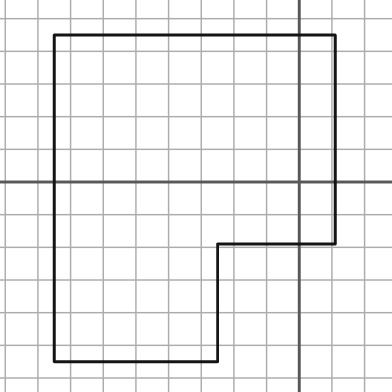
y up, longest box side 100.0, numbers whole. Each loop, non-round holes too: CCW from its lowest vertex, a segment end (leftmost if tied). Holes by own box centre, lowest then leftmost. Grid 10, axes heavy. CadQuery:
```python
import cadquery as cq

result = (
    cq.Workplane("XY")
    .moveTo(-75.0, -55.0)
    .lineTo(-25.0, -55.0)
    .lineTo(-25.0, -19.0)
    .lineTo(11.0, -19.0)
    .lineTo(11.0, 45.0)
    .lineTo(-75.0, 45.0)
    .close()
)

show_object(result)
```